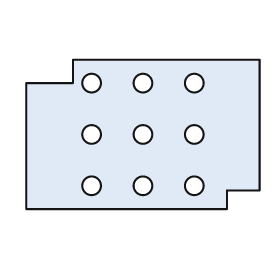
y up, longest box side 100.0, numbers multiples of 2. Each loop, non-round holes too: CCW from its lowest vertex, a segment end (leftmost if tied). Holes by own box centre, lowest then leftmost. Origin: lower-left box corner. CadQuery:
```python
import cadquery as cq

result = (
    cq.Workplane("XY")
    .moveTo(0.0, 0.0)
    .lineTo(86.0, 0.0)
    .lineTo(86.0, 8.0)
    .lineTo(100.0, 8.0)
    .lineTo(100.0, 64.0)
    .lineTo(20.0, 64.0)
    .lineTo(20.0, 54.0)
    .lineTo(0.0, 54.0)
    .close()
    .moveTo(28.0, 10.0)
    .circle(4.0)
    .moveTo(50.0, 10.0)
    .circle(4.0)
    .moveTo(72.0, 10.0)
    .circle(4.0)
    .moveTo(28.0, 32.0)
    .circle(4.0)
    .moveTo(50.0, 32.0)
    .circle(4.0)
    .moveTo(72.0, 32.0)
    .circle(4.0)
    .moveTo(28.0, 54.0)
    .circle(4.0)
    .moveTo(50.0, 54.0)
    .circle(4.0)
    .moveTo(72.0, 54.0)
    .circle(4.0)
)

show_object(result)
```